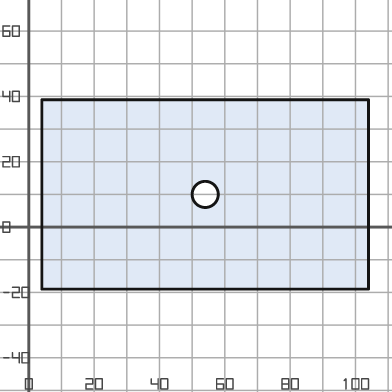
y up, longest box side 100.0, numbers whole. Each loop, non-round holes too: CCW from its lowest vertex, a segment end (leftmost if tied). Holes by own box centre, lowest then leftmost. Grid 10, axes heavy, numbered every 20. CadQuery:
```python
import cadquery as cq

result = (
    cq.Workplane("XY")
    .moveTo(4.0, -19.0)
    .lineTo(104.0, -19.0)
    .lineTo(104.0, 39.0)
    .lineTo(4.0, 39.0)
    .close()
    .moveTo(54.0, 10.0)
    .circle(4.0)
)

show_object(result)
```